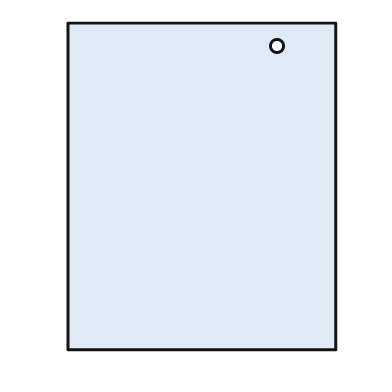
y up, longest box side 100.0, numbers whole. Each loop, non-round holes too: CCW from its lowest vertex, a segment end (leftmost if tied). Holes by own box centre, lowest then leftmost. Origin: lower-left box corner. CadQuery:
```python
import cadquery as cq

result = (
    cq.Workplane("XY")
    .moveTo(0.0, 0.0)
    .lineTo(82.0, 0.0)
    .lineTo(82.0, 100.0)
    .lineTo(0.0, 100.0)
    .close()
    .moveTo(64.0, 93.0)
    .circle(2.0)
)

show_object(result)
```